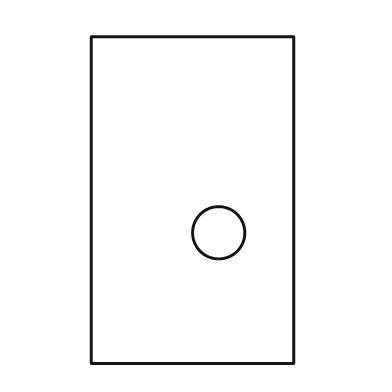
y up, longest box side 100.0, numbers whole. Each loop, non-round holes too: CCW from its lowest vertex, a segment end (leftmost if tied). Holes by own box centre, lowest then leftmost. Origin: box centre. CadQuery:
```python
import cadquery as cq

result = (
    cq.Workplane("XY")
    .moveTo(-31.0, -50.0)
    .lineTo(31.0, -50.0)
    .lineTo(31.0, 50.0)
    .lineTo(-31.0, 50.0)
    .close()
    .moveTo(8.0, -10.0)
    .circle(8.0)
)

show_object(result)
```